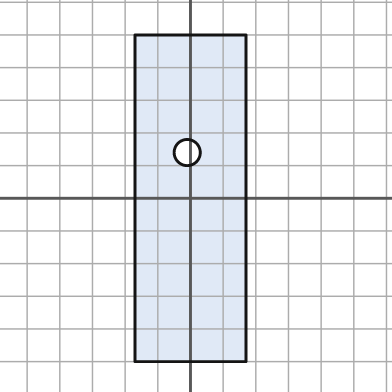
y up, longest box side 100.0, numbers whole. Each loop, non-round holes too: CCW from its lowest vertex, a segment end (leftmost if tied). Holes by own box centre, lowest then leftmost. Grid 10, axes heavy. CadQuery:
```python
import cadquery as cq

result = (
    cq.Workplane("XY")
    .moveTo(-17.0, -50.0)
    .lineTo(17.0, -50.0)
    .lineTo(17.0, 50.0)
    .lineTo(-17.0, 50.0)
    .close()
    .moveTo(-1.0, 14.0)
    .circle(4.0)
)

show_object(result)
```